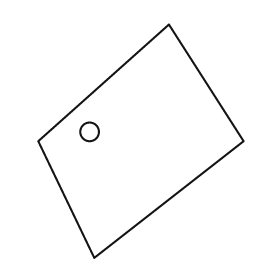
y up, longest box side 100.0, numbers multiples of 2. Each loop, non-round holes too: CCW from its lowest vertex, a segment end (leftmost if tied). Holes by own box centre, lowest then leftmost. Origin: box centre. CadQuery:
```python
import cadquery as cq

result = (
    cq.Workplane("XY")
    .moveTo(-20.0, -50.0)
    .lineTo(44.0, 0.0)
    .lineTo(12.0, 50.0)
    .lineTo(-44.0, 0.0)
    .close()
    .moveTo(-22.0, 4.0)
    .circle(4.0)
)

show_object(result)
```